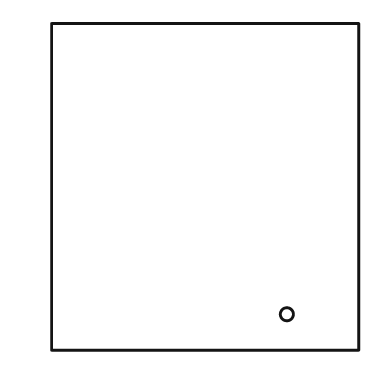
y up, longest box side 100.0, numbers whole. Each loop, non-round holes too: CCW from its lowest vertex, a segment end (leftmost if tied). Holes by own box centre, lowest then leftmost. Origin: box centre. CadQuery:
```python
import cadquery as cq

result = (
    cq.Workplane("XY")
    .moveTo(-47.0, -50.0)
    .lineTo(47.0, -50.0)
    .lineTo(47.0, 50.0)
    .lineTo(-47.0, 50.0)
    .close()
    .moveTo(25.0, -39.0)
    .circle(2.0)
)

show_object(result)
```